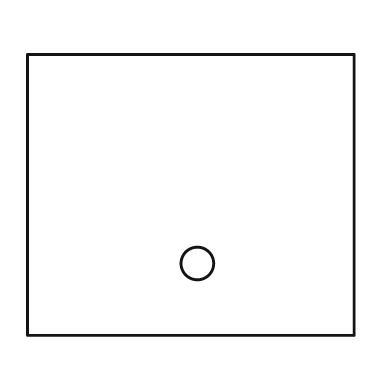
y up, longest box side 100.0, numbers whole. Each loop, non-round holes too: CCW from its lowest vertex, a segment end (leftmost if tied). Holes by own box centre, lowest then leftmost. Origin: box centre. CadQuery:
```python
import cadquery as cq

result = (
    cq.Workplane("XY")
    .moveTo(-50.0, -43.0)
    .lineTo(50.0, -43.0)
    .lineTo(50.0, 43.0)
    .lineTo(-50.0, 43.0)
    .close()
    .moveTo(2.0, -21.0)
    .circle(5.0)
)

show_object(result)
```